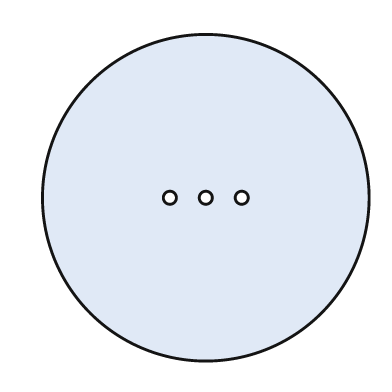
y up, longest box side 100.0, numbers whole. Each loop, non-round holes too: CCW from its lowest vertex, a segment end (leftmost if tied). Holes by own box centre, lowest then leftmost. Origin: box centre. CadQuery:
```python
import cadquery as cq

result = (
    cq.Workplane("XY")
    .moveTo(0.0, 0.0)
    .circle(50.0)
    .moveTo(-11.0, 0.0)
    .circle(2.0)
    .moveTo(0.0, 0.0)
    .circle(2.0)
    .moveTo(11.0, 0.0)
    .circle(2.0)
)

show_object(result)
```